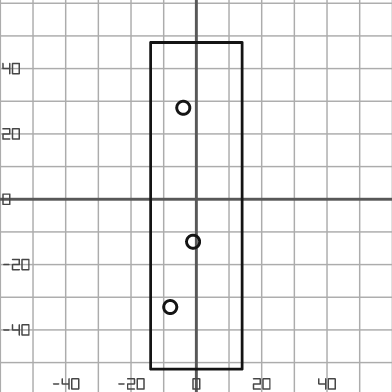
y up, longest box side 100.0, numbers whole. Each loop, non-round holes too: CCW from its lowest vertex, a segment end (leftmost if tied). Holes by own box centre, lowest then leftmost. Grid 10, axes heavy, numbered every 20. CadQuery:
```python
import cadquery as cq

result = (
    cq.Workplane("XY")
    .moveTo(-14.0, -52.0)
    .lineTo(14.0, -52.0)
    .lineTo(14.0, 48.0)
    .lineTo(-14.0, 48.0)
    .close()
    .moveTo(-8.0, -33.0)
    .circle(2.0)
    .moveTo(-1.0, -13.0)
    .circle(2.0)
    .moveTo(-4.0, 28.0)
    .circle(2.0)
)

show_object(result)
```